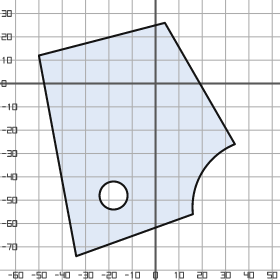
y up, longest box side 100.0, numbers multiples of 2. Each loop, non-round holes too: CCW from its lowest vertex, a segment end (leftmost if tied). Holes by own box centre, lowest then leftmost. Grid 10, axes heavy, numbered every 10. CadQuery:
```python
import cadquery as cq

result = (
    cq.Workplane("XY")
    .moveTo(-34.0, -74.0)
    .lineTo(16.0, -56.0)
    .threePointArc((20.0, -38.0), (34.0, -26.0))
    .lineTo(4.0, 26.0)
    .lineTo(-50.0, 12.0)
    .close()
    .moveTo(-18.0, -48.0)
    .circle(6.0)
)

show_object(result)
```